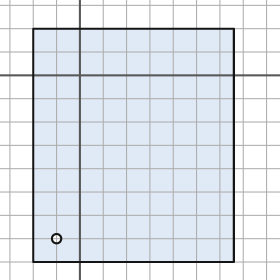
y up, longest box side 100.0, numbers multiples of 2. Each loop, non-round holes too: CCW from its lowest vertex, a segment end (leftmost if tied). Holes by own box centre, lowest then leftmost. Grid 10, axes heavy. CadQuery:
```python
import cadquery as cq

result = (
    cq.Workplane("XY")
    .moveTo(-20.0, -80.0)
    .lineTo(66.0, -80.0)
    .lineTo(66.0, 20.0)
    .lineTo(-20.0, 20.0)
    .close()
    .moveTo(-10.0, -70.0)
    .circle(2.0)
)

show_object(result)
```